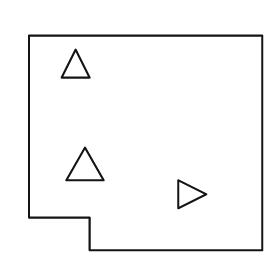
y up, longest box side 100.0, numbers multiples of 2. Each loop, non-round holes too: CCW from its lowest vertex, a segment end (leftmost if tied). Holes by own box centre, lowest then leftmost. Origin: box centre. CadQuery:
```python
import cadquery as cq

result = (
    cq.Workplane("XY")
    .moveTo(-24.0, -46.0)
    .lineTo(50.0, -46.0)
    .lineTo(50.0, 46.0)
    .lineTo(-50.0, 46.0)
    .lineTo(-50.0, -32.0)
    .lineTo(-24.0, -32.0)
    .close()
    .moveTo(14.0, -28.0)
    .lineTo(26.0, -22.0)
    .lineTo(14.0, -16.0)
    .close()
    .moveTo(-34.0, -16.0)
    .lineTo(-18.0, -16.0)
    .lineTo(-26.0, -2.0)
    .close()
    .moveTo(-36.0, 28.0)
    .lineTo(-24.0, 28.0)
    .lineTo(-30.0, 40.0)
    .close()
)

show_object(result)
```